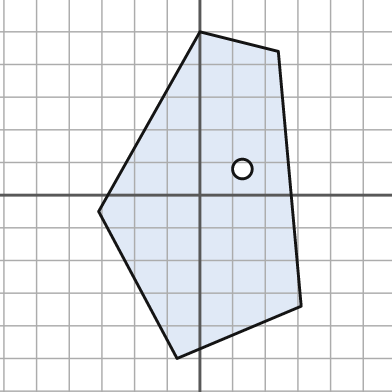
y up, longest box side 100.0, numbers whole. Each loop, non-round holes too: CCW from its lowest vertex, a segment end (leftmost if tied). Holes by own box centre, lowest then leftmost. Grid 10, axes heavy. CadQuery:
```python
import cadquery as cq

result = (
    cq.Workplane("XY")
    .moveTo(-7.0, -50.0)
    .lineTo(31.0, -34.0)
    .lineTo(24.0, 44.0)
    .lineTo(0.0, 50.0)
    .lineTo(-31.0, -5.0)
    .close()
    .moveTo(13.0, 8.0)
    .circle(3.0)
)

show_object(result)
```